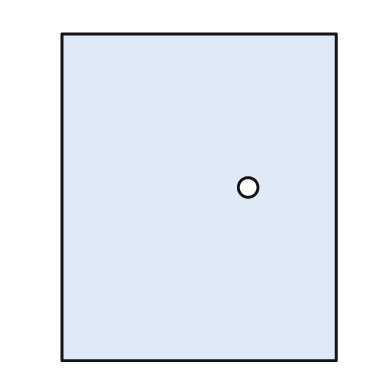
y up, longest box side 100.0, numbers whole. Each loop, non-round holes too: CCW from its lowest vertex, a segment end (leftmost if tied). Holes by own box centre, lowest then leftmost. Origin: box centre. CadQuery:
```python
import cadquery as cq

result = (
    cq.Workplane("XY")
    .moveTo(-42.0, -50.0)
    .lineTo(42.0, -50.0)
    .lineTo(42.0, 50.0)
    .lineTo(-42.0, 50.0)
    .close()
    .moveTo(15.0, 3.0)
    .circle(3.0)
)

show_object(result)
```